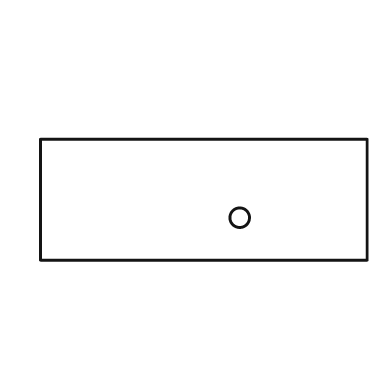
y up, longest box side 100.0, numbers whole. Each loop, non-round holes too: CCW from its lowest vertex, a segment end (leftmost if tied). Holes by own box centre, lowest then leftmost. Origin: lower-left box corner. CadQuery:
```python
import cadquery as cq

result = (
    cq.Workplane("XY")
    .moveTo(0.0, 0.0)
    .lineTo(100.0, 0.0)
    .lineTo(100.0, 37.0)
    .lineTo(0.0, 37.0)
    .close()
    .moveTo(61.0, 13.0)
    .circle(3.0)
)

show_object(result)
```